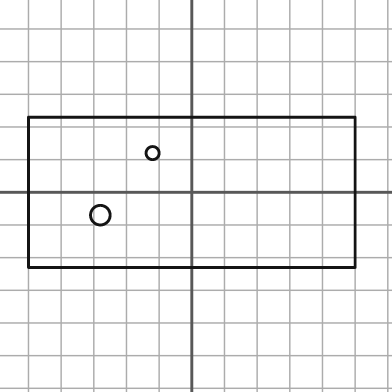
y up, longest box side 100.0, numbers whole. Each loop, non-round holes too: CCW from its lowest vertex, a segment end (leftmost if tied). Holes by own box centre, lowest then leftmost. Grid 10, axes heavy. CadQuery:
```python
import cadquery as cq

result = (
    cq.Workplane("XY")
    .moveTo(-50.0, -23.0)
    .lineTo(50.0, -23.0)
    .lineTo(50.0, 23.0)
    .lineTo(-50.0, 23.0)
    .close()
    .moveTo(-28.0, -7.0)
    .circle(3.0)
    .moveTo(-12.0, 12.0)
    .circle(2.0)
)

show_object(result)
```